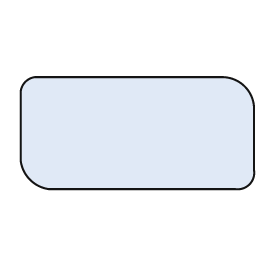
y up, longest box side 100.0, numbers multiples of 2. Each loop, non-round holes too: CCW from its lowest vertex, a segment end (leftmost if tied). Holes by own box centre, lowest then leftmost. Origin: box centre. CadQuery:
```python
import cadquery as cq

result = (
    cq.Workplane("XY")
    .moveTo(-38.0, -24.0)
    .lineTo(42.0, -24.0)
    .threePointArc((48.0, -22.0), (50.0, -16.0))
    .lineTo(50.0, 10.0)
    .threePointArc((46.0, 20.0), (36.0, 24.0))
    .lineTo(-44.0, 24.0)
    .threePointArc((-48.0, 22.0), (-50.0, 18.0))
    .lineTo(-50.0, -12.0)
    .threePointArc((-46.0, -20.0), (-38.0, -24.0))
    .close()
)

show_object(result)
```